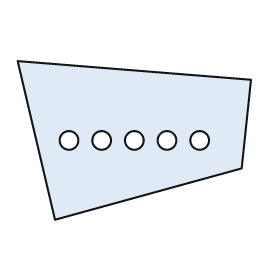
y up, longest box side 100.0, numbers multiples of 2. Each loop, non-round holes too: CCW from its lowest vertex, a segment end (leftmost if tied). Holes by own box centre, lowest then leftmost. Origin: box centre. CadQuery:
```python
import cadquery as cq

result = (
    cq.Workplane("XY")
    .moveTo(-34.0, -34.0)
    .lineTo(46.0, -12.0)
    .lineTo(50.0, 26.0)
    .lineTo(-50.0, 34.0)
    .close()
    .moveTo(-28.0, 0.0)
    .circle(4.0)
    .moveTo(-14.0, 0.0)
    .circle(4.0)
    .moveTo(0.0, 0.0)
    .circle(4.0)
    .moveTo(14.0, 0.0)
    .circle(4.0)
    .moveTo(28.0, 0.0)
    .circle(4.0)
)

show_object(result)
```